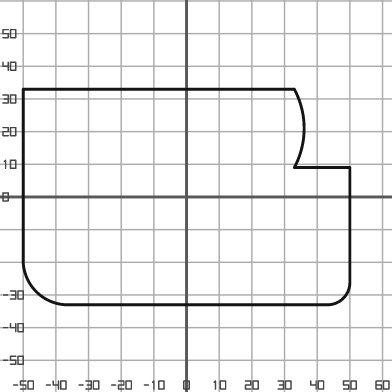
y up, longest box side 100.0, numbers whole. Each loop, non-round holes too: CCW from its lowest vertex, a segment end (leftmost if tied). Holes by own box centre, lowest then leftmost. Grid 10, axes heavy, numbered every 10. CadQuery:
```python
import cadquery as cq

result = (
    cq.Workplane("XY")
    .moveTo(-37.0, -33.0)
    .lineTo(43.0, -33.0)
    .threePointArc((48.0, -31.0), (50.0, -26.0))
    .lineTo(50.0, 9.0)
    .lineTo(33.0, 9.0)
    .threePointArc((36.0, 21.0), (33.0, 33.0))
    .lineTo(-50.0, 33.0)
    .lineTo(-50.0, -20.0)
    .threePointArc((-46.0, -29.0), (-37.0, -33.0))
    .close()
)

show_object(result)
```